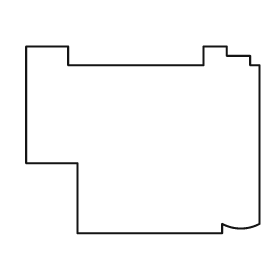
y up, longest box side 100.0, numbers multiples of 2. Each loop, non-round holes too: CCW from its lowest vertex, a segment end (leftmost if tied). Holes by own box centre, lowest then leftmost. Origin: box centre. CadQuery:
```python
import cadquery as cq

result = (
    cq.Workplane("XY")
    .moveTo(-28.0, -40.0)
    .lineTo(34.0, -40.0)
    .lineTo(34.0, -36.0)
    .threePointArc((42.0, -38.0), (50.0, -36.0))
    .lineTo(50.0, 32.0)
    .lineTo(46.0, 32.0)
    .lineTo(46.0, 36.0)
    .lineTo(36.0, 36.0)
    .lineTo(36.0, 40.0)
    .lineTo(26.0, 40.0)
    .lineTo(26.0, 32.0)
    .lineTo(-32.0, 32.0)
    .lineTo(-32.0, 40.0)
    .lineTo(-50.0, 40.0)
    .lineTo(-50.0, -10.0)
    .lineTo(-28.0, -10.0)
    .close()
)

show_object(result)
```